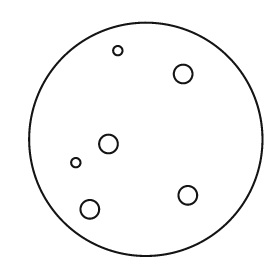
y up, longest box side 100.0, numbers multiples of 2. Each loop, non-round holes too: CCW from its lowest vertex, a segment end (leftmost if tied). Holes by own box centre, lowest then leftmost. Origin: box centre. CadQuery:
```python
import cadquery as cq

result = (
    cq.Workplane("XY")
    .moveTo(0.0, 0.0)
    .circle(50.0)
    .moveTo(-24.0, -30.0)
    .circle(4.0)
    .moveTo(18.0, -24.0)
    .circle(4.0)
    .moveTo(-30.0, -10.0)
    .circle(2.0)
    .moveTo(-16.0, -2.0)
    .circle(4.0)
    .moveTo(16.0, 28.0)
    .circle(4.0)
    .moveTo(-12.0, 38.0)
    .circle(2.0)
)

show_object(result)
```